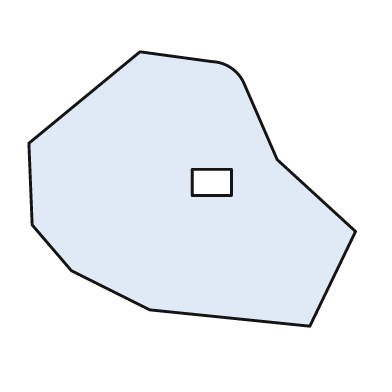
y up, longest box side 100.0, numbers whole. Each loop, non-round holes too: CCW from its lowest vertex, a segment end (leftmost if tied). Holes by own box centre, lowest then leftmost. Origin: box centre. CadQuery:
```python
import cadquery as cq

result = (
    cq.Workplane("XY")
    .moveTo(36.0, -42.0)
    .lineTo(50.0, -13.0)
    .lineTo(26.0, 9.0)
    .lineTo(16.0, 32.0)
    .threePointArc((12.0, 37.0), (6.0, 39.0))
    .lineTo(-16.0, 42.0)
    .lineTo(-50.0, 14.0)
    .lineTo(-49.0, -11.0)
    .lineTo(-37.0, -25.0)
    .lineTo(-13.0, -37.0)
    .close()
    .moveTo(0.0, -2.0)
    .lineTo(12.0, -2.0)
    .lineTo(12.0, 6.0)
    .lineTo(0.0, 6.0)
    .close()
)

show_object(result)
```